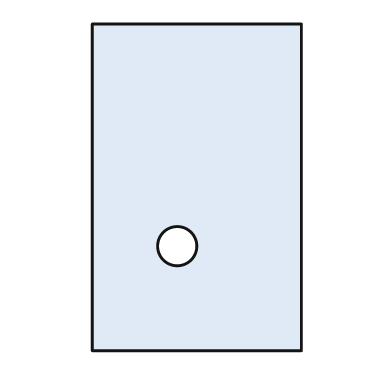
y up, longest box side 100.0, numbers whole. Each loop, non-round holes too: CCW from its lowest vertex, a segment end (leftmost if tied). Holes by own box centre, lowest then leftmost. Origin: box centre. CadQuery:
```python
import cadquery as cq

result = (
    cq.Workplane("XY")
    .moveTo(-32.0, -50.0)
    .lineTo(32.0, -50.0)
    .lineTo(32.0, 50.0)
    .lineTo(-32.0, 50.0)
    .close()
    .moveTo(-6.0, -18.0)
    .circle(6.0)
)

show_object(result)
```